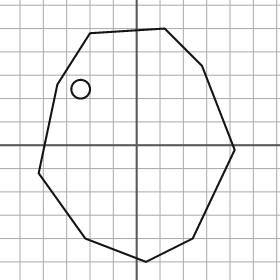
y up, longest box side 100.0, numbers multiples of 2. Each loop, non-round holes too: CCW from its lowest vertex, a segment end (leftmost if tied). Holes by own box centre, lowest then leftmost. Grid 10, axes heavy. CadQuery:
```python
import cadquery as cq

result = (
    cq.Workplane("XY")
    .moveTo(4.0, -50.0)
    .lineTo(24.0, -40.0)
    .lineTo(42.0, -2.0)
    .lineTo(28.0, 34.0)
    .lineTo(12.0, 50.0)
    .lineTo(-20.0, 48.0)
    .lineTo(-34.0, 26.0)
    .lineTo(-42.0, -12.0)
    .lineTo(-22.0, -40.0)
    .close()
    .moveTo(-24.0, 24.0)
    .circle(4.0)
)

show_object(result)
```